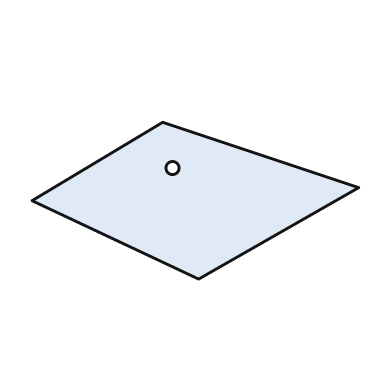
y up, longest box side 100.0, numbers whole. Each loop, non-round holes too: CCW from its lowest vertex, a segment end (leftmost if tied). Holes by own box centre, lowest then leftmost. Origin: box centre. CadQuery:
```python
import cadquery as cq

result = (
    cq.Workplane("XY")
    .moveTo(1.0, -24.0)
    .lineTo(50.0, 4.0)
    .lineTo(-10.0, 24.0)
    .lineTo(-50.0, 0.0)
    .close()
    .moveTo(-7.0, 10.0)
    .circle(2.0)
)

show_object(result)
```